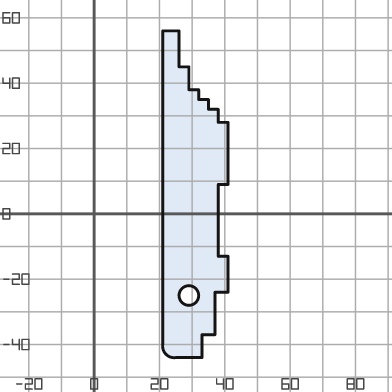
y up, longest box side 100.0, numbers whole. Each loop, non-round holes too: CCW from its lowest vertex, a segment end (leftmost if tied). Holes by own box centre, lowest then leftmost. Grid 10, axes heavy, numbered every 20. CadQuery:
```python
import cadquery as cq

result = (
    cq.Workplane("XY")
    .moveTo(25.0, -44.0)
    .lineTo(33.0, -44.0)
    .lineTo(33.0, -37.0)
    .lineTo(37.0, -37.0)
    .lineTo(37.0, -24.0)
    .lineTo(41.0, -24.0)
    .lineTo(41.0, -13.0)
    .lineTo(38.0, -13.0)
    .lineTo(38.0, 9.0)
    .lineTo(41.0, 9.0)
    .lineTo(41.0, 28.0)
    .lineTo(38.0, 28.0)
    .lineTo(38.0, 32.0)
    .lineTo(35.0, 32.0)
    .lineTo(35.0, 35.0)
    .lineTo(32.0, 35.0)
    .lineTo(32.0, 38.0)
    .lineTo(29.0, 38.0)
    .lineTo(29.0, 45.0)
    .lineTo(26.0, 45.0)
    .lineTo(26.0, 56.0)
    .lineTo(21.0, 56.0)
    .lineTo(21.0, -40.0)
    .threePointArc((22.0, -43.0), (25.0, -44.0))
    .close()
    .moveTo(29.0, -25.0)
    .circle(3.0)
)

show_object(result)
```